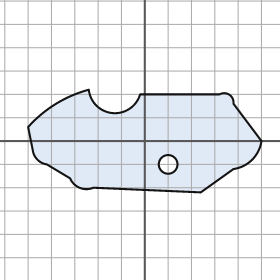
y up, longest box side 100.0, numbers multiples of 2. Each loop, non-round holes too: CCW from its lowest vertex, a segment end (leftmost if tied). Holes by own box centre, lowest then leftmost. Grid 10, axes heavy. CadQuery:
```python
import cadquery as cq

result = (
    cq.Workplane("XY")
    .moveTo(24.0, -22.0)
    .lineTo(38.0, -12.0)
    .threePointArc((46.0, -8.0), (50.0, 0.0))
    .lineTo(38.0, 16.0)
    .threePointArc((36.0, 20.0), (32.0, 20.0))
    .lineTo(-2.0, 20.0)
    .threePointArc((-14.0, 12.0), (-24.0, 22.0))
    .threePointArc((-38.0, 16.0), (-50.0, 6.0))
    .lineTo(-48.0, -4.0)
    .threePointArc((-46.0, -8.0), (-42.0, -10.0))
    .lineTo(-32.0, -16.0)
    .threePointArc((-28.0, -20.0), (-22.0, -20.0))
    .close()
    .moveTo(10.0, -10.0)
    .circle(4.0)
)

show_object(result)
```